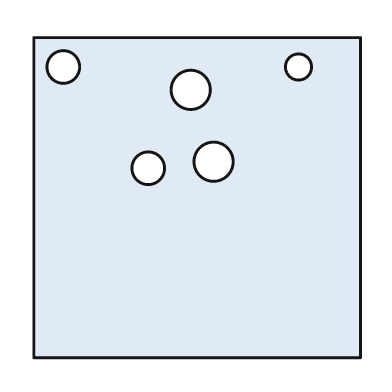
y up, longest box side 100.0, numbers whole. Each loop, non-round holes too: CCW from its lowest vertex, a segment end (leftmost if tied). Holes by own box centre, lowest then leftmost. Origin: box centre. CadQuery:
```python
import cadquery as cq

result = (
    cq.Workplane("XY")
    .moveTo(-50.0, -49.0)
    .lineTo(50.0, -49.0)
    .lineTo(50.0, 49.0)
    .lineTo(-50.0, 49.0)
    .close()
    .moveTo(-15.0, 9.0)
    .circle(5.0)
    .moveTo(5.0, 11.0)
    .circle(6.0)
    .moveTo(-2.0, 33.0)
    .circle(6.0)
    .moveTo(-41.0, 40.0)
    .circle(5.0)
    .moveTo(31.0, 40.0)
    .circle(4.0)
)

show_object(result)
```